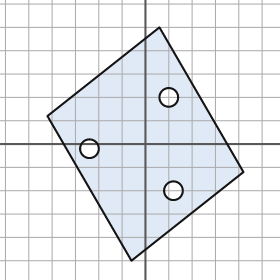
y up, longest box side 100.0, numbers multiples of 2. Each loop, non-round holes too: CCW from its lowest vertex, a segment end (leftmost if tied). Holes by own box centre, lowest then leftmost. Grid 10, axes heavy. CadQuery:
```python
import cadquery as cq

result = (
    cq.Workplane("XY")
    .moveTo(-6.0, -50.0)
    .lineTo(42.0, -12.0)
    .lineTo(6.0, 50.0)
    .lineTo(-42.0, 12.0)
    .close()
    .moveTo(12.0, -20.0)
    .circle(4.0)
    .moveTo(-24.0, -2.0)
    .circle(4.0)
    .moveTo(10.0, 20.0)
    .circle(4.0)
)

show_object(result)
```